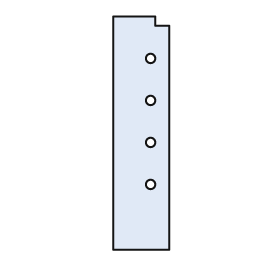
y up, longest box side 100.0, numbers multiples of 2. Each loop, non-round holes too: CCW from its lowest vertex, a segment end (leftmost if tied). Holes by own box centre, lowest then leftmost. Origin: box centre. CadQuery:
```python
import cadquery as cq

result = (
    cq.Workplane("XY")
    .moveTo(-12.0, -50.0)
    .lineTo(12.0, -50.0)
    .lineTo(12.0, 46.0)
    .lineTo(6.0, 46.0)
    .lineTo(6.0, 50.0)
    .lineTo(-12.0, 50.0)
    .close()
    .moveTo(4.0, -22.0)
    .circle(2.0)
    .moveTo(4.0, -4.0)
    .circle(2.0)
    .moveTo(4.0, 14.0)
    .circle(2.0)
    .moveTo(4.0, 32.0)
    .circle(2.0)
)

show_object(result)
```